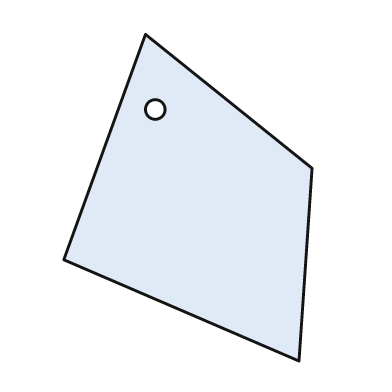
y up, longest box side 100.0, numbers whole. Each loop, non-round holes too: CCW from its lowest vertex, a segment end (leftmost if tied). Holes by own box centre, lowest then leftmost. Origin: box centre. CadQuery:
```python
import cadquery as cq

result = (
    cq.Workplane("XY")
    .moveTo(34.0, -50.0)
    .lineTo(38.0, 9.0)
    .lineTo(-13.0, 50.0)
    .lineTo(-38.0, -19.0)
    .close()
    .moveTo(-10.0, 27.0)
    .circle(3.0)
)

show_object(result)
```